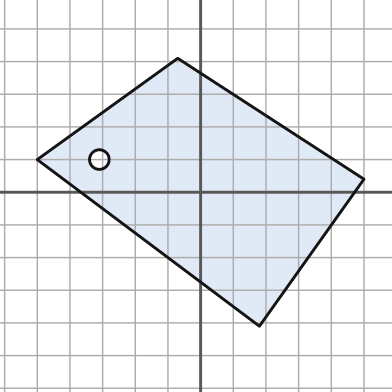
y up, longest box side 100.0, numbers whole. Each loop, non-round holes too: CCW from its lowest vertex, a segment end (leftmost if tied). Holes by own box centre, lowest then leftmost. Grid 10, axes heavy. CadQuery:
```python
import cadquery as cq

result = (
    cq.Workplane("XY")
    .moveTo(18.0, -41.0)
    .lineTo(50.0, 4.0)
    .lineTo(-7.0, 41.0)
    .lineTo(-50.0, 10.0)
    .close()
    .moveTo(-31.0, 10.0)
    .circle(3.0)
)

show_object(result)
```